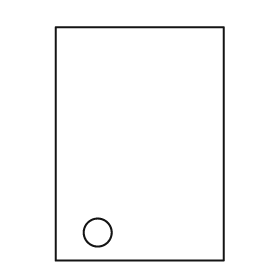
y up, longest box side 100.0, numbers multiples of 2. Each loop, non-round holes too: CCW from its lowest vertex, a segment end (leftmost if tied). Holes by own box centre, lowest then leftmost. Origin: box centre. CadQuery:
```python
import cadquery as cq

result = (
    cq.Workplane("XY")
    .moveTo(-36.0, -50.0)
    .lineTo(36.0, -50.0)
    .lineTo(36.0, 50.0)
    .lineTo(-36.0, 50.0)
    .close()
    .moveTo(-18.0, -38.0)
    .circle(6.0)
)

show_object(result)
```